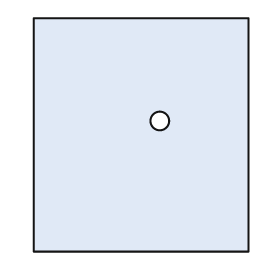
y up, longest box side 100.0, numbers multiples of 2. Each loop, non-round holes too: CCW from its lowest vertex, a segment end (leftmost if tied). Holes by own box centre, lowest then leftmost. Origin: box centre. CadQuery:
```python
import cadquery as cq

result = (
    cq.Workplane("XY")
    .moveTo(-46.0, -50.0)
    .lineTo(46.0, -50.0)
    .lineTo(46.0, 50.0)
    .lineTo(-46.0, 50.0)
    .close()
    .moveTo(8.0, 6.0)
    .circle(4.0)
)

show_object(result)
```